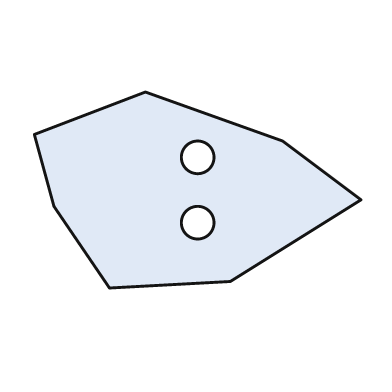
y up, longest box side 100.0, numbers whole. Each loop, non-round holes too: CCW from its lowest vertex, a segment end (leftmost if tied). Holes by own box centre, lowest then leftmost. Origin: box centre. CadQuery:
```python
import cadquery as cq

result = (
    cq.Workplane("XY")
    .moveTo(-27.0, -30.0)
    .lineTo(10.0, -28.0)
    .lineTo(50.0, -3.0)
    .lineTo(26.0, 15.0)
    .lineTo(-16.0, 30.0)
    .lineTo(-50.0, 17.0)
    .lineTo(-44.0, -5.0)
    .close()
    .moveTo(0.0, -10.0)
    .circle(5.0)
    .moveTo(0.0, 10.0)
    .circle(5.0)
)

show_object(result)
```